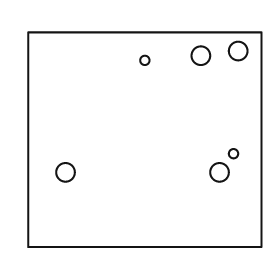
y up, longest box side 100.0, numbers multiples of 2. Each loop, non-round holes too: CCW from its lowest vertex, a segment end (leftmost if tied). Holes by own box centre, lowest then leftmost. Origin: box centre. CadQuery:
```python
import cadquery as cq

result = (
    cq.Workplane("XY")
    .moveTo(-50.0, -46.0)
    .lineTo(50.0, -46.0)
    .lineTo(50.0, 46.0)
    .lineTo(-50.0, 46.0)
    .close()
    .moveTo(-34.0, -14.0)
    .circle(4.0)
    .moveTo(32.0, -14.0)
    .circle(4.0)
    .moveTo(38.0, -6.0)
    .circle(2.0)
    .moveTo(0.0, 34.0)
    .circle(2.0)
    .moveTo(24.0, 36.0)
    .circle(4.0)
    .moveTo(40.0, 38.0)
    .circle(4.0)
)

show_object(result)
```